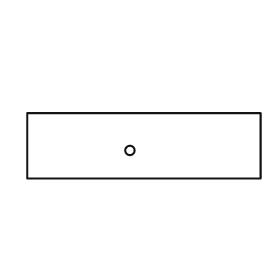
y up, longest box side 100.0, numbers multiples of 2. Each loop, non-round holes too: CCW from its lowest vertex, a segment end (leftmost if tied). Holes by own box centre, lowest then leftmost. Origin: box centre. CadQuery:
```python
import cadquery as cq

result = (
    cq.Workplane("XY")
    .moveTo(-50.0, -14.0)
    .lineTo(50.0, -14.0)
    .lineTo(50.0, 14.0)
    .lineTo(-50.0, 14.0)
    .close()
    .moveTo(-6.0, -2.0)
    .circle(2.0)
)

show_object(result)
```